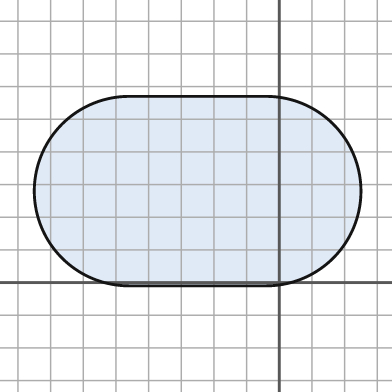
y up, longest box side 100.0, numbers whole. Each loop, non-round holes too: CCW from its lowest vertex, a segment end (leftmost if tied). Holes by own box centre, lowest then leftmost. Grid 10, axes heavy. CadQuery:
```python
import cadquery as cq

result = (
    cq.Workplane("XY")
    .moveTo(-46.0, -1.0)
    .lineTo(-4.0, -1.0)
    .threePointArc((25.0, 28.0), (-4.0, 57.0))
    .lineTo(-46.0, 57.0)
    .threePointArc((-75.0, 28.0), (-46.0, -1.0))
    .close()
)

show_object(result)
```